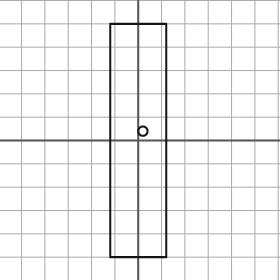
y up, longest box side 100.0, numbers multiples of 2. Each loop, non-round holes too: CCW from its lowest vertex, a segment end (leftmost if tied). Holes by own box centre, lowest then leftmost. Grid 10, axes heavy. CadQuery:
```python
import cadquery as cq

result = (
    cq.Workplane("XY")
    .moveTo(-12.0, -50.0)
    .lineTo(12.0, -50.0)
    .lineTo(12.0, 50.0)
    .lineTo(-12.0, 50.0)
    .close()
    .moveTo(2.0, 4.0)
    .circle(2.0)
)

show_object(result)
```